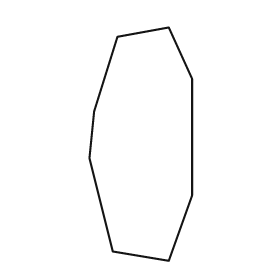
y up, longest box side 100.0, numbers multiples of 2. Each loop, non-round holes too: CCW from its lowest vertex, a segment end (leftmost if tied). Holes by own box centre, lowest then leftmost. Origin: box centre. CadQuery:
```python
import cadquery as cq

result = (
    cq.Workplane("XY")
    .moveTo(12.0, -50.0)
    .lineTo(22.0, -22.0)
    .lineTo(22.0, 28.0)
    .lineTo(12.0, 50.0)
    .lineTo(-10.0, 46.0)
    .lineTo(-20.0, 14.0)
    .lineTo(-22.0, -6.0)
    .lineTo(-12.0, -46.0)
    .close()
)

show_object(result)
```